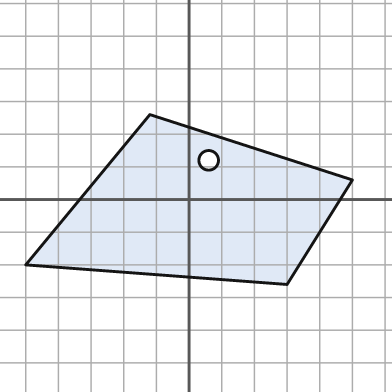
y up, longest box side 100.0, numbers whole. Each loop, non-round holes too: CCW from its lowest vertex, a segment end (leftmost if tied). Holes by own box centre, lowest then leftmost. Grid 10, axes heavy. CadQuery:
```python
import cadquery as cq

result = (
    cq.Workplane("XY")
    .moveTo(30.0, -26.0)
    .lineTo(50.0, 6.0)
    .lineTo(-12.0, 26.0)
    .lineTo(-50.0, -20.0)
    .close()
    .moveTo(6.0, 12.0)
    .circle(3.0)
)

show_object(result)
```